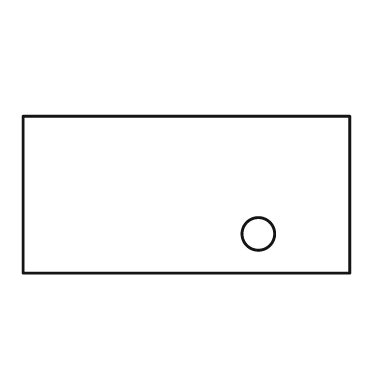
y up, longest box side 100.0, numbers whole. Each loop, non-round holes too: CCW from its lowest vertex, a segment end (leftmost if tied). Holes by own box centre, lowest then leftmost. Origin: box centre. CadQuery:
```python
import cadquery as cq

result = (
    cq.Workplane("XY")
    .moveTo(-50.0, -24.0)
    .lineTo(50.0, -24.0)
    .lineTo(50.0, 24.0)
    .lineTo(-50.0, 24.0)
    .close()
    .moveTo(22.0, -12.0)
    .circle(5.0)
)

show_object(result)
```